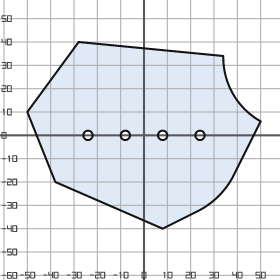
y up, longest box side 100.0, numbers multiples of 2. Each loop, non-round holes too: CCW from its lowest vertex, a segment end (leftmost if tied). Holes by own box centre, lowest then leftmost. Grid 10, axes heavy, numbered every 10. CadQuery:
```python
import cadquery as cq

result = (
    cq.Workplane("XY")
    .moveTo(8.0, -40.0)
    .lineTo(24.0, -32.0)
    .threePointArc((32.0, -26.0), (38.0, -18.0))
    .lineTo(50.0, 6.0)
    .threePointArc((38.0, 18.0), (34.0, 34.0))
    .lineTo(-28.0, 40.0)
    .lineTo(-50.0, 10.0)
    .lineTo(-38.0, -20.0)
    .close()
    .moveTo(-24.0, 0.0)
    .circle(2.0)
    .moveTo(-8.0, 0.0)
    .circle(2.0)
    .moveTo(8.0, 0.0)
    .circle(2.0)
    .moveTo(24.0, 0.0)
    .circle(2.0)
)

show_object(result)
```